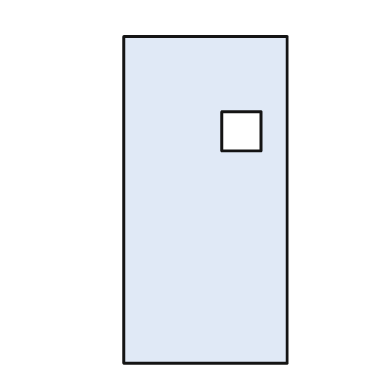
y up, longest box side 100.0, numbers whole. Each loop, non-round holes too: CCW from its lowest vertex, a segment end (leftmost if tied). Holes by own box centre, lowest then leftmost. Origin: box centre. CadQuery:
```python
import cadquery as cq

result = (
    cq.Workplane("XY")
    .moveTo(-25.0, -50.0)
    .lineTo(25.0, -50.0)
    .lineTo(25.0, 50.0)
    .lineTo(-25.0, 50.0)
    .close()
    .moveTo(5.0, 15.0)
    .lineTo(17.0, 15.0)
    .lineTo(17.0, 27.0)
    .lineTo(5.0, 27.0)
    .close()
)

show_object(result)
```